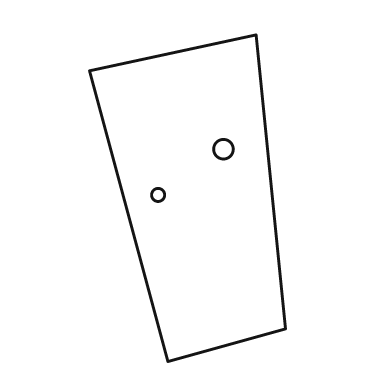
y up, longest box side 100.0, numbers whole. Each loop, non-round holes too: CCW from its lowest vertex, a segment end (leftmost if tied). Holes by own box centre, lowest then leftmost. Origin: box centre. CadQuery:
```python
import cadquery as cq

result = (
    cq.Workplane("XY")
    .moveTo(-6.0, -50.0)
    .lineTo(30.0, -40.0)
    .lineTo(21.0, 50.0)
    .lineTo(-30.0, 39.0)
    .close()
    .moveTo(-9.0, 1.0)
    .circle(2.0)
    .moveTo(11.0, 15.0)
    .circle(3.0)
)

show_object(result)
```